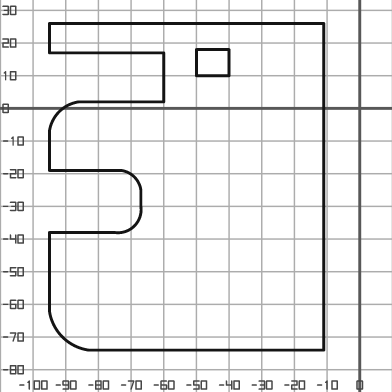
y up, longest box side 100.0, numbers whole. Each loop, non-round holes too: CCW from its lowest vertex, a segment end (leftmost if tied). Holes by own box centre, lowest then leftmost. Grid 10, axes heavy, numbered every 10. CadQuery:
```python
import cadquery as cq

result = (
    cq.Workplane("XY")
    .moveTo(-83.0, -74.0)
    .lineTo(-11.0, -74.0)
    .lineTo(-11.0, 26.0)
    .lineTo(-95.0, 26.0)
    .lineTo(-95.0, 17.0)
    .lineTo(-60.0, 17.0)
    .lineTo(-60.0, 2.0)
    .lineTo(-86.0, 2.0)
    .threePointArc((-92.0, -1.0), (-95.0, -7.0))
    .lineTo(-95.0, -19.0)
    .lineTo(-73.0, -19.0)
    .threePointArc((-69.0, -21.0), (-67.0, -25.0))
    .lineTo(-67.0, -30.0)
    .threePointArc((-69.0, -36.0), (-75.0, -38.0))
    .lineTo(-95.0, -38.0)
    .lineTo(-95.0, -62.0)
    .threePointArc((-91.0, -70.0), (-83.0, -74.0))
    .close()
    .moveTo(-50.0, 10.0)
    .lineTo(-40.0, 10.0)
    .lineTo(-40.0, 18.0)
    .lineTo(-50.0, 18.0)
    .close()
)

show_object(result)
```